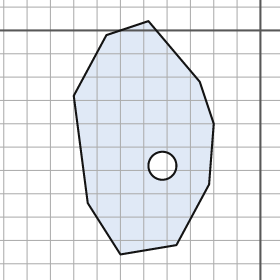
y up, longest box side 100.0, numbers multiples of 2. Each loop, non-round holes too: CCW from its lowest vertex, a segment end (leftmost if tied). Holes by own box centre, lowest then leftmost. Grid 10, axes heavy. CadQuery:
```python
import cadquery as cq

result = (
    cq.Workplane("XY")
    .moveTo(-60.0, -96.0)
    .lineTo(-36.0, -92.0)
    .lineTo(-22.0, -66.0)
    .lineTo(-20.0, -40.0)
    .lineTo(-26.0, -22.0)
    .lineTo(-48.0, 4.0)
    .lineTo(-66.0, -2.0)
    .lineTo(-80.0, -28.0)
    .lineTo(-74.0, -74.0)
    .close()
    .moveTo(-42.0, -58.0)
    .circle(6.0)
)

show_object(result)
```